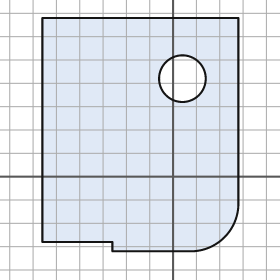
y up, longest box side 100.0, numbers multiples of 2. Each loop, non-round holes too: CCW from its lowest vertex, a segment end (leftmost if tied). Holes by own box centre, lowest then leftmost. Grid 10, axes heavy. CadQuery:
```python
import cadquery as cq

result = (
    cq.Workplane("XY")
    .moveTo(-26.0, -32.0)
    .lineTo(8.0, -32.0)
    .threePointArc((22.0, -26.0), (28.0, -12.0))
    .lineTo(28.0, 68.0)
    .lineTo(-56.0, 68.0)
    .lineTo(-56.0, -28.0)
    .lineTo(-26.0, -28.0)
    .close()
    .moveTo(4.0, 42.0)
    .circle(10.0)
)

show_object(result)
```